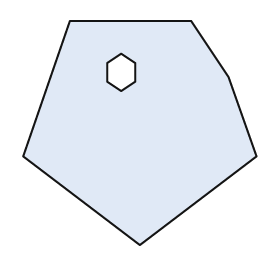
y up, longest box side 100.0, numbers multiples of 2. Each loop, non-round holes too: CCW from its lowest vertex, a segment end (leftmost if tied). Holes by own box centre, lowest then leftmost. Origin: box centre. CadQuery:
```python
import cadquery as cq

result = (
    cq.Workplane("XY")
    .moveTo(0.0, -48.0)
    .lineTo(50.0, -10.0)
    .lineTo(38.0, 24.0)
    .lineTo(22.0, 48.0)
    .lineTo(-30.0, 48.0)
    .lineTo(-50.0, -10.0)
    .close()
    .moveTo(-8.0, 18.0)
    .lineTo(-2.0, 22.0)
    .lineTo(-2.0, 30.0)
    .lineTo(-8.0, 34.0)
    .lineTo(-14.0, 30.0)
    .lineTo(-14.0, 22.0)
    .close()
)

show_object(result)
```